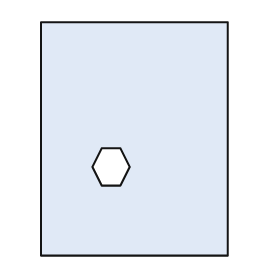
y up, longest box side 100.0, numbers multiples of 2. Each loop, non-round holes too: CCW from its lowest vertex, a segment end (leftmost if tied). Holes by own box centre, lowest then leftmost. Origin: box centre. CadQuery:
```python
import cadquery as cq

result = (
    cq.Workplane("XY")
    .moveTo(-40.0, -50.0)
    .lineTo(40.0, -50.0)
    .lineTo(40.0, 50.0)
    .lineTo(-40.0, 50.0)
    .close()
    .moveTo(-14.0, -20.0)
    .lineTo(-6.0, -20.0)
    .lineTo(-2.0, -12.0)
    .lineTo(-6.0, -4.0)
    .lineTo(-14.0, -4.0)
    .lineTo(-18.0, -12.0)
    .close()
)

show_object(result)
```